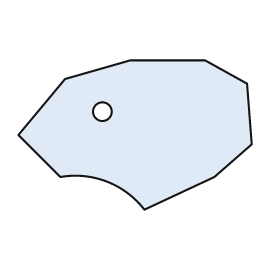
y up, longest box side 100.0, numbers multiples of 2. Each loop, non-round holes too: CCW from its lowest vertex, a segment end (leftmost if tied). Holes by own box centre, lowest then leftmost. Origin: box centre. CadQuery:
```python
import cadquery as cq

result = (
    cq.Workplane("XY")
    .moveTo(4.0, -32.0)
    .lineTo(34.0, -18.0)
    .lineTo(50.0, -4.0)
    .lineTo(48.0, 22.0)
    .lineTo(30.0, 32.0)
    .lineTo(-2.0, 32.0)
    .lineTo(-30.0, 24.0)
    .lineTo(-50.0, 0.0)
    .lineTo(-32.0, -18.0)
    .threePointArc((-12.0, -20.0), (4.0, -32.0))
    .close()
    .moveTo(-14.0, 10.0)
    .circle(4.0)
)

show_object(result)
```